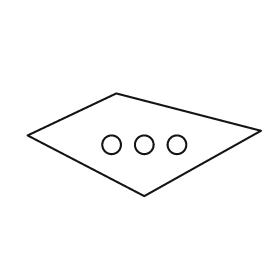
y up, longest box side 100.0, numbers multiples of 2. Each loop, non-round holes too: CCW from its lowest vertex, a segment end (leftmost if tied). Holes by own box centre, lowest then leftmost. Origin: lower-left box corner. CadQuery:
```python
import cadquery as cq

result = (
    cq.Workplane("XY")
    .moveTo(50.0, 0.0)
    .lineTo(100.0, 28.0)
    .lineTo(38.0, 44.0)
    .lineTo(0.0, 26.0)
    .close()
    .moveTo(36.0, 22.0)
    .circle(4.0)
    .moveTo(50.0, 22.0)
    .circle(4.0)
    .moveTo(64.0, 22.0)
    .circle(4.0)
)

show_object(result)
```